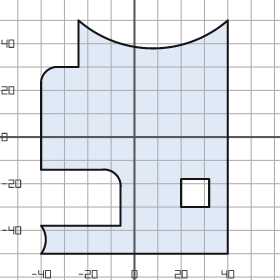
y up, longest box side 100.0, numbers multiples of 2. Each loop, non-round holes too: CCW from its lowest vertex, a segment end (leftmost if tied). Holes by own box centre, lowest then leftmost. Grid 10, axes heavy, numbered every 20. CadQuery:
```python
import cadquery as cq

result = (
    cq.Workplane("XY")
    .moveTo(-40.0, -50.0)
    .lineTo(40.0, -50.0)
    .lineTo(40.0, 50.0)
    .threePointArc((8.0, 38.0), (-24.0, 50.0))
    .lineTo(-24.0, 30.0)
    .lineTo(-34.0, 30.0)
    .threePointArc((-38.0, 28.0), (-40.0, 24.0))
    .lineTo(-40.0, -14.0)
    .lineTo(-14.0, -14.0)
    .threePointArc((-8.0, -16.0), (-6.0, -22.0))
    .lineTo(-6.0, -38.0)
    .lineTo(-40.0, -38.0)
    .threePointArc((-38.0, -44.0), (-40.0, -50.0))
    .close()
    .moveTo(20.0, -30.0)
    .lineTo(32.0, -30.0)
    .lineTo(32.0, -18.0)
    .lineTo(20.0, -18.0)
    .close()
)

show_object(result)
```